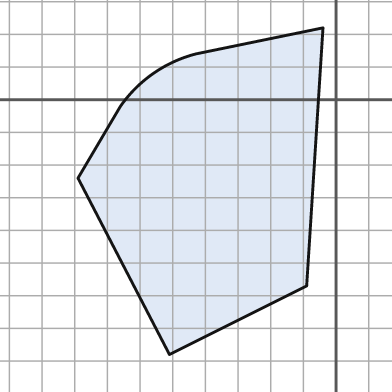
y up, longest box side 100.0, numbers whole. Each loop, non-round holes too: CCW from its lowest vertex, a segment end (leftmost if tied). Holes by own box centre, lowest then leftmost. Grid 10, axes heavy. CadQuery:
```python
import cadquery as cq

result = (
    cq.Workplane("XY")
    .moveTo(-51.0, -78.0)
    .lineTo(-9.0, -57.0)
    .lineTo(-4.0, 22.0)
    .lineTo(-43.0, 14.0)
    .threePointArc((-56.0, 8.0), (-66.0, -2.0))
    .lineTo(-79.0, -24.0)
    .close()
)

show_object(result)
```